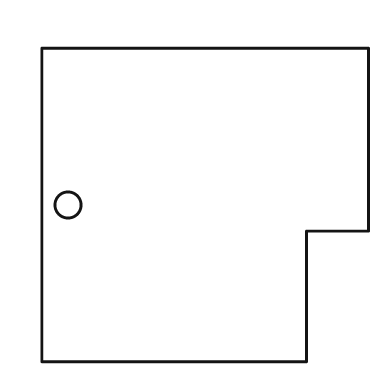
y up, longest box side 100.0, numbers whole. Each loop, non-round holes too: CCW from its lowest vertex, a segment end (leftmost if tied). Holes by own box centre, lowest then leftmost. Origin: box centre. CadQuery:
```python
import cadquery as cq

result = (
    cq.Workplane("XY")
    .moveTo(-50.0, -48.0)
    .lineTo(31.0, -48.0)
    .lineTo(31.0, -8.0)
    .lineTo(50.0, -8.0)
    .lineTo(50.0, 48.0)
    .lineTo(-50.0, 48.0)
    .close()
    .moveTo(-42.0, 0.0)
    .circle(4.0)
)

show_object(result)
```